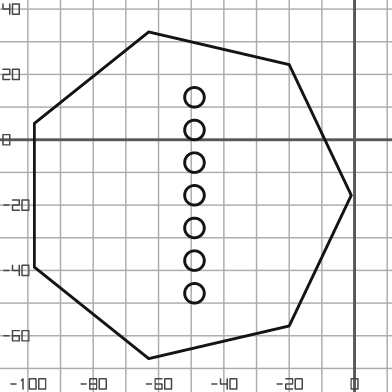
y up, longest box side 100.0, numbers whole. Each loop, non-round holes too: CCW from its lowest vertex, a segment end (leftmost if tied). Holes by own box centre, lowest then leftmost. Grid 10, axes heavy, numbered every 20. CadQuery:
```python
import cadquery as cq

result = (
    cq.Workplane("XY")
    .moveTo(-63.0, -67.0)
    .lineTo(-20.0, -57.0)
    .lineTo(-1.0, -17.0)
    .lineTo(-20.0, 23.0)
    .lineTo(-63.0, 33.0)
    .lineTo(-98.0, 5.0)
    .lineTo(-98.0, -39.0)
    .close()
    .moveTo(-49.0, -47.0)
    .circle(3.0)
    .moveTo(-49.0, -37.0)
    .circle(3.0)
    .moveTo(-49.0, -27.0)
    .circle(3.0)
    .moveTo(-49.0, -17.0)
    .circle(3.0)
    .moveTo(-49.0, -7.0)
    .circle(3.0)
    .moveTo(-49.0, 3.0)
    .circle(3.0)
    .moveTo(-49.0, 13.0)
    .circle(3.0)
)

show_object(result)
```